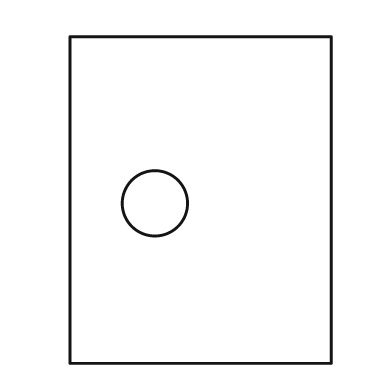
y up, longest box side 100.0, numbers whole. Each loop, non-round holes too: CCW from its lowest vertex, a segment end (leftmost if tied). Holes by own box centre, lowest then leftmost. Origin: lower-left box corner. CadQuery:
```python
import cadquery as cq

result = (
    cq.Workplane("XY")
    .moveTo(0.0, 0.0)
    .lineTo(80.0, 0.0)
    .lineTo(80.0, 100.0)
    .lineTo(0.0, 100.0)
    .close()
    .moveTo(26.0, 49.0)
    .circle(10.0)
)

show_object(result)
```